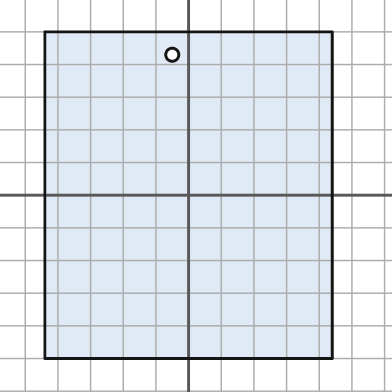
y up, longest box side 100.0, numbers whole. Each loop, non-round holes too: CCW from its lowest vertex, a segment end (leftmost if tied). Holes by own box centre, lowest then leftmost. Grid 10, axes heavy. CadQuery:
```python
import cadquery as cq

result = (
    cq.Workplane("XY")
    .moveTo(-44.0, -50.0)
    .lineTo(44.0, -50.0)
    .lineTo(44.0, 50.0)
    .lineTo(-44.0, 50.0)
    .close()
    .moveTo(-5.0, 43.0)
    .circle(2.0)
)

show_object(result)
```